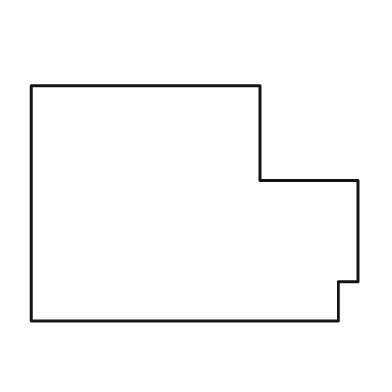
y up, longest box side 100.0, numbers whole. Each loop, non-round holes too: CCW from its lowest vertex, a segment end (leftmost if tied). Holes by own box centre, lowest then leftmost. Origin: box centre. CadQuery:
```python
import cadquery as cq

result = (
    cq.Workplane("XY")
    .moveTo(-50.0, -36.0)
    .lineTo(44.0, -36.0)
    .lineTo(44.0, -24.0)
    .lineTo(50.0, -24.0)
    .lineTo(50.0, 7.0)
    .lineTo(20.0, 7.0)
    .lineTo(20.0, 36.0)
    .lineTo(-50.0, 36.0)
    .close()
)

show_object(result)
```